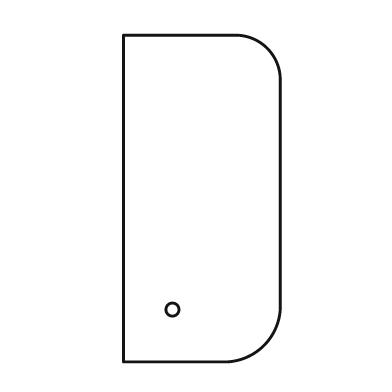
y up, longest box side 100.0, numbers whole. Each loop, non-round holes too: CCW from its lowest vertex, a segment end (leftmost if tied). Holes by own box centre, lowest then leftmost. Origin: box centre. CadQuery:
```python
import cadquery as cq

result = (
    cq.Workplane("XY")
    .moveTo(-24.0, -50.0)
    .lineTo(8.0, -50.0)
    .threePointArc((19.0, -45.0), (24.0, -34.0))
    .lineTo(24.0, 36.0)
    .threePointArc((20.0, 46.0), (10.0, 50.0))
    .lineTo(-24.0, 50.0)
    .close()
    .moveTo(-9.0, -34.0)
    .circle(2.0)
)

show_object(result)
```